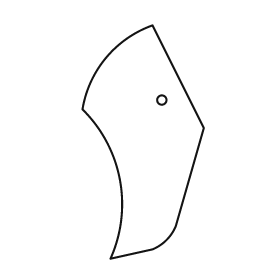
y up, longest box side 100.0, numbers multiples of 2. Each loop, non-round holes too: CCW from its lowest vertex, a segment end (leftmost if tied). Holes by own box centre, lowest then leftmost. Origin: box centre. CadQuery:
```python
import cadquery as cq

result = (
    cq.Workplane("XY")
    .moveTo(-14.0, -50.0)
    .lineTo(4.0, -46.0)
    .threePointArc((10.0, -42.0), (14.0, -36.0))
    .lineTo(26.0, 6.0)
    .lineTo(4.0, 50.0)
    .threePointArc((-16.0, 36.0), (-26.0, 14.0))
    .threePointArc((-10.0, -16.0), (-14.0, -50.0))
    .close()
    .moveTo(8.0, 18.0)
    .circle(2.0)
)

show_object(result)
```